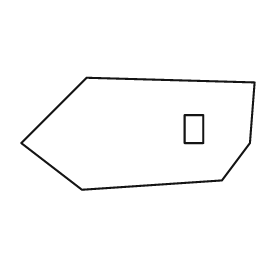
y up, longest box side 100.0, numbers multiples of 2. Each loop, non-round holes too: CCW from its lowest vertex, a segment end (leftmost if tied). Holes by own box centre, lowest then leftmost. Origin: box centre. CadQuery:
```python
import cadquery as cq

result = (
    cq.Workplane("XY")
    .moveTo(-24.0, -24.0)
    .lineTo(36.0, -20.0)
    .lineTo(48.0, -4.0)
    .lineTo(50.0, 22.0)
    .lineTo(-22.0, 24.0)
    .lineTo(-50.0, -4.0)
    .close()
    .moveTo(20.0, -4.0)
    .lineTo(28.0, -4.0)
    .lineTo(28.0, 8.0)
    .lineTo(20.0, 8.0)
    .close()
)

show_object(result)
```